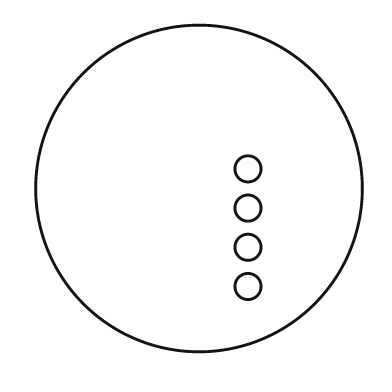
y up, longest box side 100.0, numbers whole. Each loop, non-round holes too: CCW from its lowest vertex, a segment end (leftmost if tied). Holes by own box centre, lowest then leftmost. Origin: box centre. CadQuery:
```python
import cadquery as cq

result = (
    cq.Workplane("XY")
    .moveTo(0.0, 0.0)
    .circle(50.0)
    .moveTo(15.0, -30.0)
    .circle(4.0)
    .moveTo(15.0, -18.0)
    .circle(4.0)
    .moveTo(15.0, -6.0)
    .circle(4.0)
    .moveTo(15.0, 6.0)
    .circle(4.0)
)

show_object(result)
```